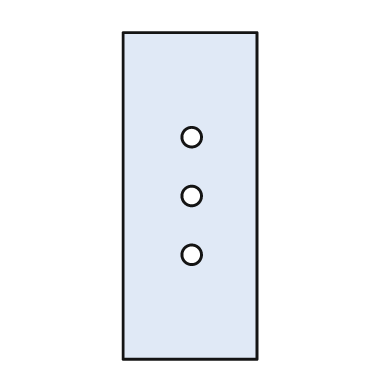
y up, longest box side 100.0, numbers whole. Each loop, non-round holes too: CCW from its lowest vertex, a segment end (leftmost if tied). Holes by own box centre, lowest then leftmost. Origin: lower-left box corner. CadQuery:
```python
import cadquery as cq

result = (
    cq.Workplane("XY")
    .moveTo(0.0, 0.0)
    .lineTo(41.0, 0.0)
    .lineTo(41.0, 100.0)
    .lineTo(0.0, 100.0)
    .close()
    .moveTo(21.0, 32.0)
    .circle(3.0)
    .moveTo(21.0, 50.0)
    .circle(3.0)
    .moveTo(21.0, 68.0)
    .circle(3.0)
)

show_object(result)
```